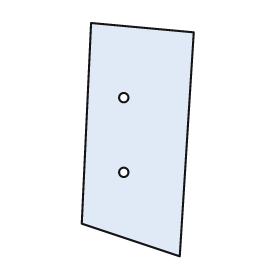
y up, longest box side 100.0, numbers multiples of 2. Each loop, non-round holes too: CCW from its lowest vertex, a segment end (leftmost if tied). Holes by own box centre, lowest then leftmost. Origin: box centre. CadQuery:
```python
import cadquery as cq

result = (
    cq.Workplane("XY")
    .moveTo(18.0, -50.0)
    .lineTo(24.0, 46.0)
    .lineTo(-20.0, 50.0)
    .lineTo(-24.0, -36.0)
    .close()
    .moveTo(-6.0, -14.0)
    .circle(2.0)
    .moveTo(-6.0, 18.0)
    .circle(2.0)
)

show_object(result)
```